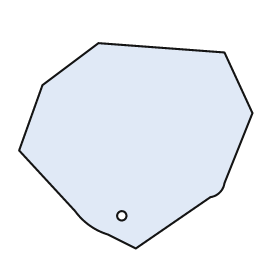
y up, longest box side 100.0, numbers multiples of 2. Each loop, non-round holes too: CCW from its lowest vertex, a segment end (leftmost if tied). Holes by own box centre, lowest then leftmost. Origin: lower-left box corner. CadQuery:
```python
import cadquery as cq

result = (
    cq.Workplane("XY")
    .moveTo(50.0, 0.0)
    .lineTo(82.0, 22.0)
    .threePointArc((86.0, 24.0), (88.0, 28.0))
    .lineTo(100.0, 58.0)
    .lineTo(88.0, 84.0)
    .lineTo(34.0, 88.0)
    .lineTo(10.0, 70.0)
    .lineTo(0.0, 42.0)
    .lineTo(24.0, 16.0)
    .threePointArc((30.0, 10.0), (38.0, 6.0))
    .close()
    .moveTo(44.0, 14.0)
    .circle(2.0)
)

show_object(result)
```